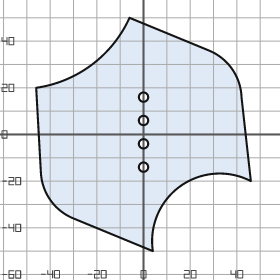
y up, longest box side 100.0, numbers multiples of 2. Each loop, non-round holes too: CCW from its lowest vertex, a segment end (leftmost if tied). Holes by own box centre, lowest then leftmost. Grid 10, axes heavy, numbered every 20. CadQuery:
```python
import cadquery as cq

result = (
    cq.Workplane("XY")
    .moveTo(4.0, -50.0)
    .threePointArc((16.0, -22.0), (46.0, -20.0))
    .lineTo(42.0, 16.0)
    .threePointArc((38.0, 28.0), (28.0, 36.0))
    .lineTo(-6.0, 50.0)
    .threePointArc((-22.0, 30.0), (-46.0, 20.0))
    .lineTo(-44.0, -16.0)
    .threePointArc((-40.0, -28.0), (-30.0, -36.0))
    .close()
    .moveTo(0.0, -14.0)
    .circle(2.0)
    .moveTo(0.0, -4.0)
    .circle(2.0)
    .moveTo(0.0, 6.0)
    .circle(2.0)
    .moveTo(0.0, 16.0)
    .circle(2.0)
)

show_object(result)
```